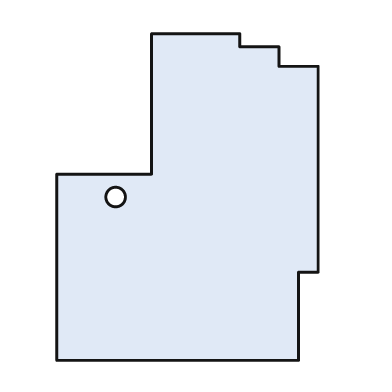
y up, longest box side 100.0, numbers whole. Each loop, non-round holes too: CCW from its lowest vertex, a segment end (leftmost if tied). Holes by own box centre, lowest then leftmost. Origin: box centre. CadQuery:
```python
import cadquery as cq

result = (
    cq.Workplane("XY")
    .moveTo(-40.0, -50.0)
    .lineTo(34.0, -50.0)
    .lineTo(34.0, -23.0)
    .lineTo(40.0, -23.0)
    .lineTo(40.0, 40.0)
    .lineTo(28.0, 40.0)
    .lineTo(28.0, 46.0)
    .lineTo(16.0, 46.0)
    .lineTo(16.0, 50.0)
    .lineTo(-11.0, 50.0)
    .lineTo(-11.0, 7.0)
    .lineTo(-40.0, 7.0)
    .close()
    .moveTo(-22.0, 0.0)
    .circle(3.0)
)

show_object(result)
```